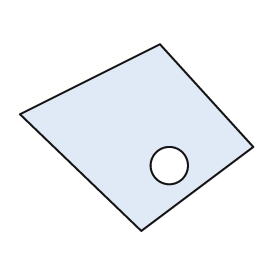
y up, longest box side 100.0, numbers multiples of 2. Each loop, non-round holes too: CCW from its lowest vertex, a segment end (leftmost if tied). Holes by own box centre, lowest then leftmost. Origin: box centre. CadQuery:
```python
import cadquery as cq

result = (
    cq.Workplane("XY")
    .moveTo(2.0, -40.0)
    .lineTo(50.0, -4.0)
    .lineTo(10.0, 40.0)
    .lineTo(-50.0, 10.0)
    .close()
    .moveTo(14.0, -12.0)
    .circle(8.0)
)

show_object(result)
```